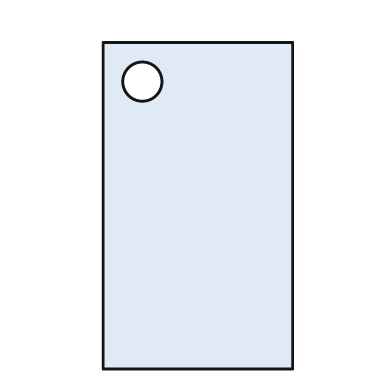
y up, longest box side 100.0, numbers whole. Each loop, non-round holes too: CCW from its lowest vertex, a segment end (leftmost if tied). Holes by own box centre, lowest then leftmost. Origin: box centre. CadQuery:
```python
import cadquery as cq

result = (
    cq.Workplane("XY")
    .moveTo(-29.0, -50.0)
    .lineTo(29.0, -50.0)
    .lineTo(29.0, 50.0)
    .lineTo(-29.0, 50.0)
    .close()
    .moveTo(-17.0, 38.0)
    .circle(6.0)
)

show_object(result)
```